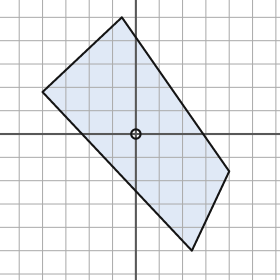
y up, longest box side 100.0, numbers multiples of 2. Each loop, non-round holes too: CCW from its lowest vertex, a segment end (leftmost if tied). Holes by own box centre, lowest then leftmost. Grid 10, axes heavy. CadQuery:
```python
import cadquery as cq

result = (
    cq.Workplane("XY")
    .moveTo(24.0, -50.0)
    .lineTo(40.0, -16.0)
    .lineTo(-6.0, 50.0)
    .lineTo(-40.0, 18.0)
    .close()
    .moveTo(0.0, 0.0)
    .circle(2.0)
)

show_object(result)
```